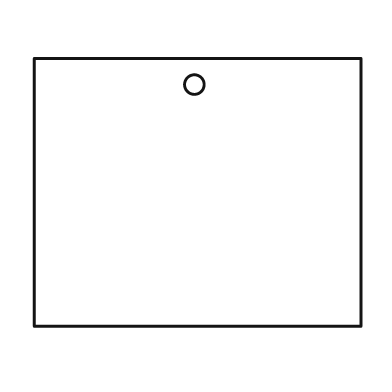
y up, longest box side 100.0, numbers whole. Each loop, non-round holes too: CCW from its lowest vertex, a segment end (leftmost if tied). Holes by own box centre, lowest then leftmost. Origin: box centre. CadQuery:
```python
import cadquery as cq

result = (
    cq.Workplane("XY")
    .moveTo(-50.0, -41.0)
    .lineTo(50.0, -41.0)
    .lineTo(50.0, 41.0)
    .lineTo(-50.0, 41.0)
    .close()
    .moveTo(-1.0, 33.0)
    .circle(3.0)
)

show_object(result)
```